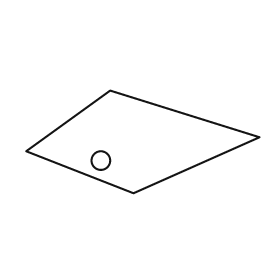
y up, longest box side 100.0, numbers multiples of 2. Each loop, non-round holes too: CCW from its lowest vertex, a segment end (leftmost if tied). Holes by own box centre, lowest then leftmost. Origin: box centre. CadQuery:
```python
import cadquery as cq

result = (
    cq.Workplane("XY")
    .moveTo(-4.0, -22.0)
    .lineTo(50.0, 2.0)
    .lineTo(-14.0, 22.0)
    .lineTo(-50.0, -4.0)
    .close()
    .moveTo(-18.0, -8.0)
    .circle(4.0)
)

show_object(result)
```